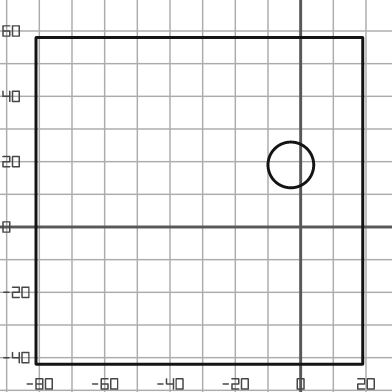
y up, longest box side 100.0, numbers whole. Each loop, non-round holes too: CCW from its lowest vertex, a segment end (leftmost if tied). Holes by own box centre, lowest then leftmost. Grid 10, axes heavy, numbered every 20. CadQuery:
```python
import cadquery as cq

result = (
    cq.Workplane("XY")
    .moveTo(-81.0, -42.0)
    .lineTo(19.0, -42.0)
    .lineTo(19.0, 58.0)
    .lineTo(-81.0, 58.0)
    .close()
    .moveTo(-3.0, 19.0)
    .circle(7.0)
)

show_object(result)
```